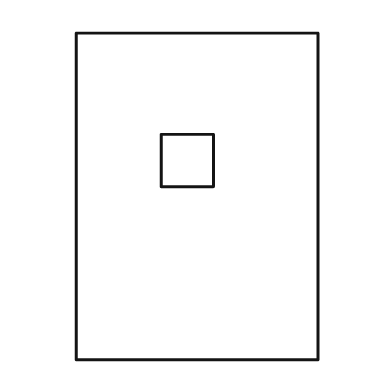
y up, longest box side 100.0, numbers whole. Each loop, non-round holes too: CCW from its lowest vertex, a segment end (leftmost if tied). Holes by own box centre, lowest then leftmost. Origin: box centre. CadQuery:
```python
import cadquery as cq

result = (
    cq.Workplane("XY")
    .moveTo(-37.0, -50.0)
    .lineTo(37.0, -50.0)
    .lineTo(37.0, 50.0)
    .lineTo(-37.0, 50.0)
    .close()
    .moveTo(-11.0, 3.0)
    .lineTo(5.0, 3.0)
    .lineTo(5.0, 19.0)
    .lineTo(-11.0, 19.0)
    .close()
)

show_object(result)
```